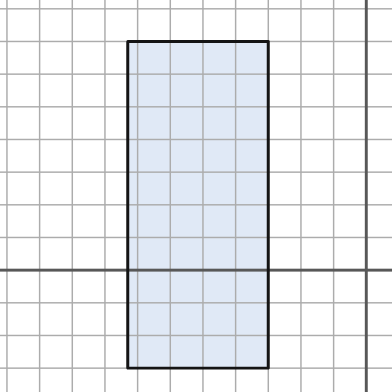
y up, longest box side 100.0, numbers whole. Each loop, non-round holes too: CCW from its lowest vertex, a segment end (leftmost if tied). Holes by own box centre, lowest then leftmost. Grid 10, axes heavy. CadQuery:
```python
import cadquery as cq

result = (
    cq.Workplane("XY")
    .moveTo(-73.0, -30.0)
    .lineTo(-30.0, -30.0)
    .lineTo(-30.0, 70.0)
    .lineTo(-73.0, 70.0)
    .close()
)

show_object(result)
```